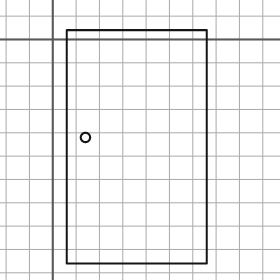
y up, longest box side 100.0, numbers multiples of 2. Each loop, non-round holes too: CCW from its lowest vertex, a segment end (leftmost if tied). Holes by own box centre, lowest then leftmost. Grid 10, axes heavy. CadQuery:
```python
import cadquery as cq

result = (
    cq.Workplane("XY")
    .moveTo(6.0, -96.0)
    .lineTo(66.0, -96.0)
    .lineTo(66.0, 4.0)
    .lineTo(6.0, 4.0)
    .close()
    .moveTo(14.0, -42.0)
    .circle(2.0)
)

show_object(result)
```